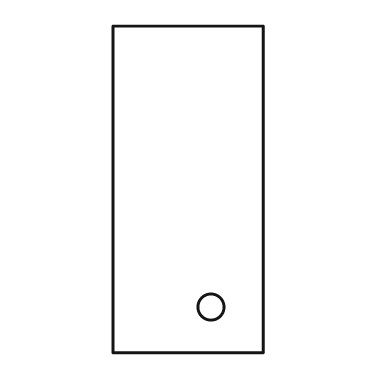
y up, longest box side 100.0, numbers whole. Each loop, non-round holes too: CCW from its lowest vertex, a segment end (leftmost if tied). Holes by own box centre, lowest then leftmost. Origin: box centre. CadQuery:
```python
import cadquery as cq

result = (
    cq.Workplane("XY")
    .moveTo(-23.0, -50.0)
    .lineTo(23.0, -50.0)
    .lineTo(23.0, 50.0)
    .lineTo(-23.0, 50.0)
    .close()
    .moveTo(7.0, -36.0)
    .circle(4.0)
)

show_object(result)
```